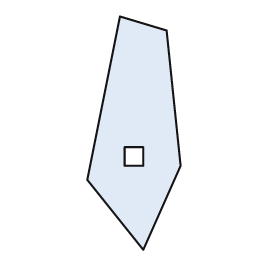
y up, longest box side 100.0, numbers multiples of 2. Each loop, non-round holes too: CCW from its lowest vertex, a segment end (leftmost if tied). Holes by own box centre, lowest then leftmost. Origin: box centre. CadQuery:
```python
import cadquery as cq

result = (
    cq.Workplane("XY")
    .moveTo(4.0, -50.0)
    .lineTo(20.0, -14.0)
    .lineTo(14.0, 44.0)
    .lineTo(-6.0, 50.0)
    .lineTo(-20.0, -20.0)
    .close()
    .moveTo(-4.0, -14.0)
    .lineTo(4.0, -14.0)
    .lineTo(4.0, -6.0)
    .lineTo(-4.0, -6.0)
    .close()
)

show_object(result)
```